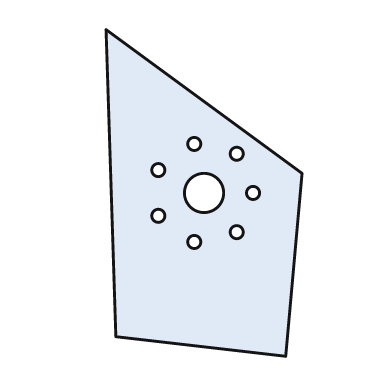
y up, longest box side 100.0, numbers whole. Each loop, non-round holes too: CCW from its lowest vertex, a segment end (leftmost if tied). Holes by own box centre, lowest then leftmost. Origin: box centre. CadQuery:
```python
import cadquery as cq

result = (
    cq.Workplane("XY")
    .moveTo(25.0, -50.0)
    .lineTo(30.0, 6.0)
    .lineTo(-30.0, 50.0)
    .lineTo(-27.0, -44.0)
    .close()
    .moveTo(-3.0, -15.0)
    .circle(2.0)
    .moveTo(10.0, -12.0)
    .circle(2.0)
    .moveTo(-14.0, -7.0)
    .circle(2.0)
    .moveTo(0.0, 0.0)
    .circle(6.0)
    .moveTo(15.0, 0.0)
    .circle(2.0)
    .moveTo(-14.0, 7.0)
    .circle(2.0)
    .moveTo(10.0, 12.0)
    .circle(2.0)
    .moveTo(-3.0, 15.0)
    .circle(2.0)
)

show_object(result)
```